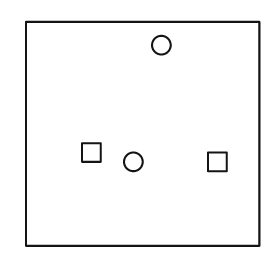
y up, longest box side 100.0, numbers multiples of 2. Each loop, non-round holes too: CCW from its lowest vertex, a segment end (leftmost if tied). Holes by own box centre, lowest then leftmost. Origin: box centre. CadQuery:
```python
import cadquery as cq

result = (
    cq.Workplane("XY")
    .moveTo(-50.0, -48.0)
    .lineTo(50.0, -48.0)
    .lineTo(50.0, 48.0)
    .lineTo(-50.0, 48.0)
    .close()
    .moveTo(-4.0, -12.0)
    .circle(4.0)
    .moveTo(28.0, -16.0)
    .lineTo(36.0, -16.0)
    .lineTo(36.0, -8.0)
    .lineTo(28.0, -8.0)
    .close()
    .moveTo(-26.0, -12.0)
    .lineTo(-18.0, -12.0)
    .lineTo(-18.0, -4.0)
    .lineTo(-26.0, -4.0)
    .close()
    .moveTo(8.0, 38.0)
    .circle(4.0)
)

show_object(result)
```